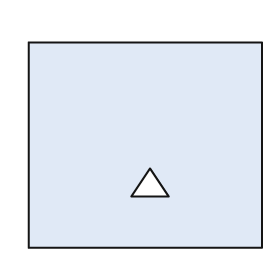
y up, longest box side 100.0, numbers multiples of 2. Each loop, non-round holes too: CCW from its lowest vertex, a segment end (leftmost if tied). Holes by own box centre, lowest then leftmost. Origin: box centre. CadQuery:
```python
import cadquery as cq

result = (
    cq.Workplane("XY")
    .moveTo(-50.0, -44.0)
    .lineTo(50.0, -44.0)
    .lineTo(50.0, 44.0)
    .lineTo(-50.0, 44.0)
    .close()
    .moveTo(-6.0, -22.0)
    .lineTo(10.0, -22.0)
    .lineTo(2.0, -10.0)
    .close()
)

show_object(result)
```